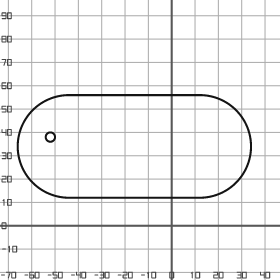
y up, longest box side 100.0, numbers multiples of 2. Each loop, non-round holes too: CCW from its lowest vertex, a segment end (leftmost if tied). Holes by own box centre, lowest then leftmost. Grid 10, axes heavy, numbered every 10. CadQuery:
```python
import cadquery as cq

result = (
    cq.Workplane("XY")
    .moveTo(-44.0, 12.0)
    .lineTo(12.0, 12.0)
    .threePointArc((34.0, 34.0), (12.0, 56.0))
    .lineTo(-44.0, 56.0)
    .threePointArc((-66.0, 34.0), (-44.0, 12.0))
    .close()
    .moveTo(-52.0, 38.0)
    .circle(2.0)
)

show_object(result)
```